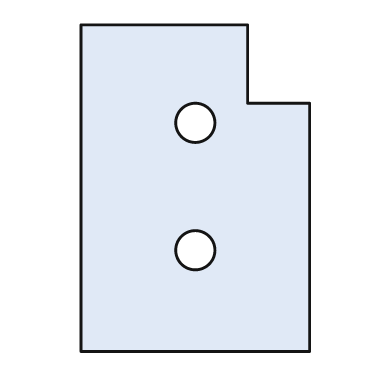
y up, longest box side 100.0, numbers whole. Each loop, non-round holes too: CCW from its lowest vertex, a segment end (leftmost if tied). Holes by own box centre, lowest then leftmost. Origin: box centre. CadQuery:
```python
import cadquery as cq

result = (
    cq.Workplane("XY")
    .moveTo(-35.0, -50.0)
    .lineTo(35.0, -50.0)
    .lineTo(35.0, 26.0)
    .lineTo(16.0, 26.0)
    .lineTo(16.0, 50.0)
    .lineTo(-35.0, 50.0)
    .close()
    .moveTo(0.0, -19.0)
    .circle(6.0)
    .moveTo(0.0, 20.0)
    .circle(6.0)
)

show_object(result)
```